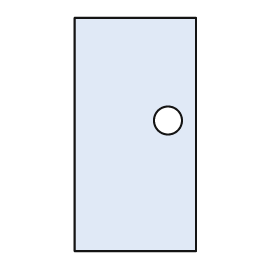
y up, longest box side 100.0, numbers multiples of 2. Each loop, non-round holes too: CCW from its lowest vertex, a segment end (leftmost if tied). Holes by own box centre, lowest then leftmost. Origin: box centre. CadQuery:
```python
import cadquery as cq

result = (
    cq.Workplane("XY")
    .moveTo(-26.0, -50.0)
    .lineTo(26.0, -50.0)
    .lineTo(26.0, 50.0)
    .lineTo(-26.0, 50.0)
    .close()
    .moveTo(14.0, 6.0)
    .circle(6.0)
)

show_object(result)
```